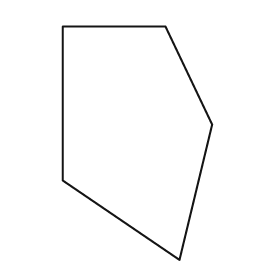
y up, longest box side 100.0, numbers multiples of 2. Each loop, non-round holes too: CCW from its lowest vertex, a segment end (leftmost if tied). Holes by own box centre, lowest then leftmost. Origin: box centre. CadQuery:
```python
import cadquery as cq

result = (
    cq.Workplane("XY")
    .moveTo(18.0, -50.0)
    .lineTo(32.0, 8.0)
    .lineTo(12.0, 50.0)
    .lineTo(-32.0, 50.0)
    .lineTo(-32.0, -16.0)
    .close()
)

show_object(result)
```